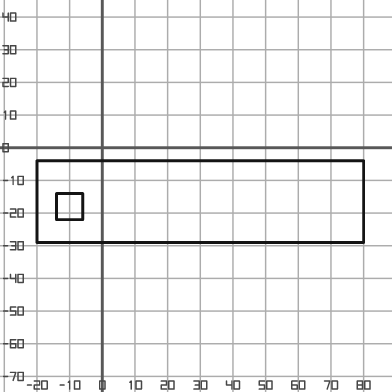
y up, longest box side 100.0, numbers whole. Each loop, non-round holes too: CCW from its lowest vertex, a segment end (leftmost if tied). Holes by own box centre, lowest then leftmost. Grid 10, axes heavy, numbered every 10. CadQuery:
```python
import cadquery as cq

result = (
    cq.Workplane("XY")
    .moveTo(-20.0, -29.0)
    .lineTo(80.0, -29.0)
    .lineTo(80.0, -4.0)
    .lineTo(-20.0, -4.0)
    .close()
    .moveTo(-14.0, -22.0)
    .lineTo(-6.0, -22.0)
    .lineTo(-6.0, -14.0)
    .lineTo(-14.0, -14.0)
    .close()
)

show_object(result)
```